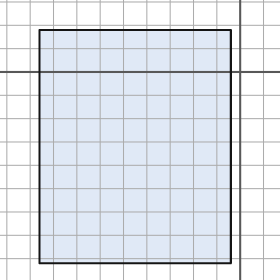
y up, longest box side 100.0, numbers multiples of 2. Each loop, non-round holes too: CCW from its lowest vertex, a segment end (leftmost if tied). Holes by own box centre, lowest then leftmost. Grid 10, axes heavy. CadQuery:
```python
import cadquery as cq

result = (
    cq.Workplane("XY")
    .moveTo(-86.0, -82.0)
    .lineTo(-4.0, -82.0)
    .lineTo(-4.0, 18.0)
    .lineTo(-86.0, 18.0)
    .close()
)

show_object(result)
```